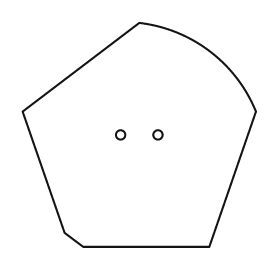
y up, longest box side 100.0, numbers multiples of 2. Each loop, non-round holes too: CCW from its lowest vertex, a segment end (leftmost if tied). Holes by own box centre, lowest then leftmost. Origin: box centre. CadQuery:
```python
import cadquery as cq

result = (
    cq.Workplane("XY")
    .moveTo(-24.0, -48.0)
    .lineTo(30.0, -48.0)
    .lineTo(50.0, 10.0)
    .threePointArc((30.0, 36.0), (0.0, 48.0))
    .lineTo(-50.0, 10.0)
    .lineTo(-32.0, -42.0)
    .close()
    .moveTo(-8.0, 0.0)
    .circle(2.0)
    .moveTo(8.0, 0.0)
    .circle(2.0)
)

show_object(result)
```